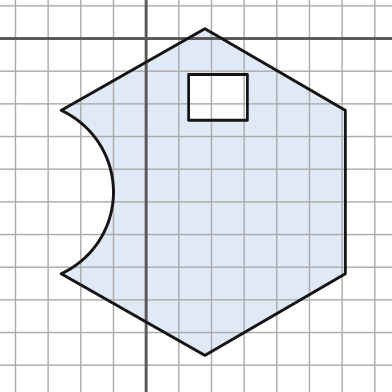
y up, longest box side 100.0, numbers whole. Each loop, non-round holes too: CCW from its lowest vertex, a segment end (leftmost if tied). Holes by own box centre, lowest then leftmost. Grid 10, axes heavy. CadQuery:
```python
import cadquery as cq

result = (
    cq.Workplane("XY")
    .moveTo(18.0, -97.0)
    .lineTo(61.0, -72.0)
    .lineTo(61.0, -22.0)
    .lineTo(18.0, 3.0)
    .lineTo(-26.0, -22.0)
    .threePointArc((-10.0, -47.0), (-26.0, -72.0))
    .close()
    .moveTo(13.0, -25.0)
    .lineTo(31.0, -25.0)
    .lineTo(31.0, -11.0)
    .lineTo(13.0, -11.0)
    .close()
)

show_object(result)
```